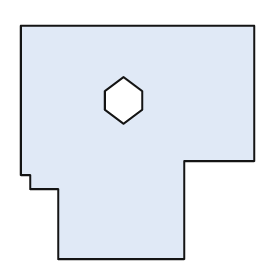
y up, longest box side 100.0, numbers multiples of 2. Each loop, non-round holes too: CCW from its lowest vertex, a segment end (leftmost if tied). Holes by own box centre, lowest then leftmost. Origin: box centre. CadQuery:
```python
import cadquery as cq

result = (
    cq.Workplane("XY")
    .moveTo(-34.0, -50.0)
    .lineTo(20.0, -50.0)
    .lineTo(20.0, -8.0)
    .lineTo(50.0, -8.0)
    .lineTo(50.0, 50.0)
    .lineTo(-50.0, 50.0)
    .lineTo(-50.0, -14.0)
    .lineTo(-46.0, -14.0)
    .lineTo(-46.0, -20.0)
    .lineTo(-34.0, -20.0)
    .close()
    .moveTo(-6.0, 8.0)
    .lineTo(2.0, 14.0)
    .lineTo(2.0, 22.0)
    .lineTo(-6.0, 28.0)
    .lineTo(-14.0, 22.0)
    .lineTo(-14.0, 14.0)
    .close()
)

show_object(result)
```